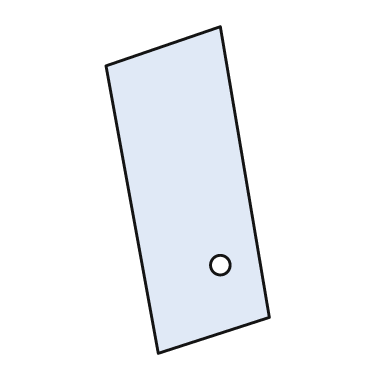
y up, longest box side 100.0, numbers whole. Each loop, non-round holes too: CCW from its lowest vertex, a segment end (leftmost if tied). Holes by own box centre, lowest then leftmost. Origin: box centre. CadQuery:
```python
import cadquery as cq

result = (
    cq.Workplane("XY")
    .moveTo(-9.0, -50.0)
    .lineTo(25.0, -39.0)
    .lineTo(10.0, 50.0)
    .lineTo(-25.0, 38.0)
    .close()
    .moveTo(10.0, -23.0)
    .circle(3.0)
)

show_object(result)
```